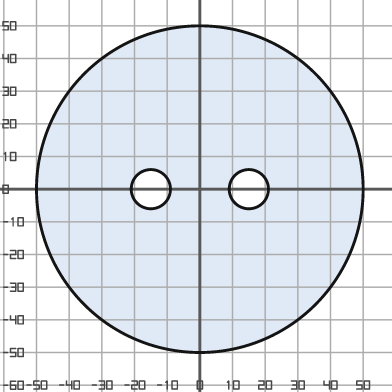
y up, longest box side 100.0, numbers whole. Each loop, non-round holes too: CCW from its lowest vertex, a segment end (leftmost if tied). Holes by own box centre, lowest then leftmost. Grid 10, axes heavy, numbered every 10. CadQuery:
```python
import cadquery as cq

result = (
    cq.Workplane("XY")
    .moveTo(0.0, 0.0)
    .circle(50.0)
    .moveTo(-15.0, 0.0)
    .circle(6.0)
    .moveTo(15.0, 0.0)
    .circle(6.0)
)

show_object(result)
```